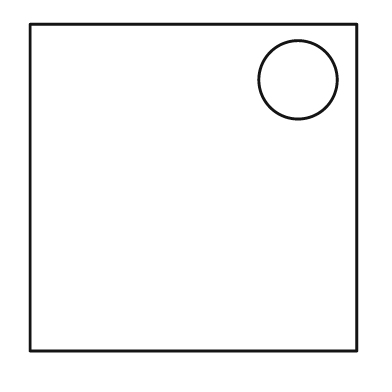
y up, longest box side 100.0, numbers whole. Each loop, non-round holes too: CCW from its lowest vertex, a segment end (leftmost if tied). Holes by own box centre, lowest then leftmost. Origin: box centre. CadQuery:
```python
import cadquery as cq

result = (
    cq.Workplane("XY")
    .moveTo(-50.0, -50.0)
    .lineTo(50.0, -50.0)
    .lineTo(50.0, 50.0)
    .lineTo(-50.0, 50.0)
    .close()
    .moveTo(32.0, 33.0)
    .circle(12.0)
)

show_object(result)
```